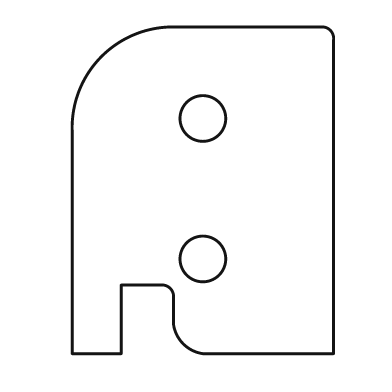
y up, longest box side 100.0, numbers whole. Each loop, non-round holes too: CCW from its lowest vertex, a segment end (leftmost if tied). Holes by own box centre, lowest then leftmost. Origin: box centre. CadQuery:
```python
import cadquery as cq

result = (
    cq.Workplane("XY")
    .moveTo(-40.0, -50.0)
    .lineTo(-25.0, -50.0)
    .lineTo(-25.0, -29.0)
    .lineTo(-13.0, -29.0)
    .threePointArc((-10.0, -30.0), (-9.0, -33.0))
    .lineTo(-9.0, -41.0)
    .threePointArc((-6.0, -47.0), (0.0, -50.0))
    .lineTo(40.0, -50.0)
    .lineTo(40.0, 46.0)
    .threePointArc((39.0, 49.0), (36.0, 50.0))
    .lineTo(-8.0, 50.0)
    .threePointArc((-31.0, 41.0), (-40.0, 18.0))
    .close()
    .moveTo(0.0, -21.0)
    .circle(7.0)
    .moveTo(0.0, 22.0)
    .circle(7.0)
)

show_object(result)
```